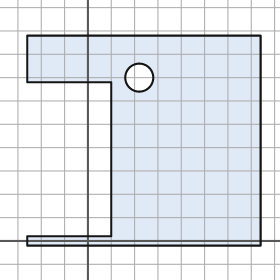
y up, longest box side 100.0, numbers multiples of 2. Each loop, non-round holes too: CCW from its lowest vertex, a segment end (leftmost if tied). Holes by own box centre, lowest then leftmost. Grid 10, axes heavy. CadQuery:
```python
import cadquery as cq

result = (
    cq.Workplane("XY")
    .moveTo(-26.0, -2.0)
    .lineTo(74.0, -2.0)
    .lineTo(74.0, 88.0)
    .lineTo(-26.0, 88.0)
    .lineTo(-26.0, 68.0)
    .lineTo(10.0, 68.0)
    .lineTo(10.0, 2.0)
    .lineTo(-26.0, 2.0)
    .close()
    .moveTo(22.0, 70.0)
    .circle(6.0)
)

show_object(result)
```